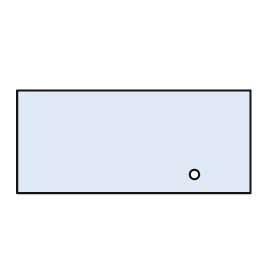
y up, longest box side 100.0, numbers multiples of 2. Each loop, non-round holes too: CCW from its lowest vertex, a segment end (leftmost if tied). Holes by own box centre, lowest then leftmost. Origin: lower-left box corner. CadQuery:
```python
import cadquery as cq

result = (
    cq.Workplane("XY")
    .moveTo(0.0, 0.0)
    .lineTo(100.0, 0.0)
    .lineTo(100.0, 44.0)
    .lineTo(0.0, 44.0)
    .close()
    .moveTo(76.0, 8.0)
    .circle(2.0)
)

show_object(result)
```